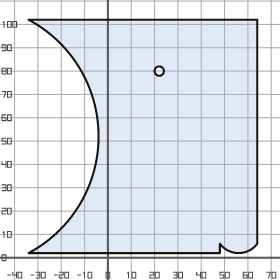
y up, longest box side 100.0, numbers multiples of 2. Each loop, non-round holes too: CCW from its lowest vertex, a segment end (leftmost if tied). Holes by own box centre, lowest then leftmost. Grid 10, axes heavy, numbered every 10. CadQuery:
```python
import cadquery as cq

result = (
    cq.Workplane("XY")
    .moveTo(-34.0, 2.0)
    .lineTo(48.0, 2.0)
    .lineTo(48.0, 6.0)
    .threePointArc((56.0, 2.0), (64.0, 6.0))
    .lineTo(64.0, 102.0)
    .lineTo(-34.0, 102.0)
    .threePointArc((-4.0, 52.0), (-34.0, 2.0))
    .close()
    .moveTo(22.0, 80.0)
    .circle(2.0)
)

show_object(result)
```